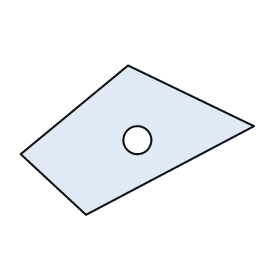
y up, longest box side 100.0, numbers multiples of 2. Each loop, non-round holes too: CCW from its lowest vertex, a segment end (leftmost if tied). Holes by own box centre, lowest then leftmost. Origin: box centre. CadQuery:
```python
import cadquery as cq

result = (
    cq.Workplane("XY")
    .moveTo(-22.0, -32.0)
    .lineTo(50.0, 6.0)
    .lineTo(-4.0, 32.0)
    .lineTo(-50.0, -6.0)
    .close()
    .moveTo(0.0, 0.0)
    .circle(6.0)
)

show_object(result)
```